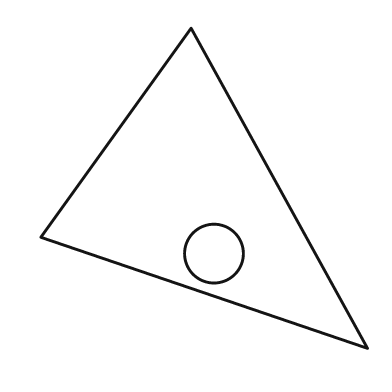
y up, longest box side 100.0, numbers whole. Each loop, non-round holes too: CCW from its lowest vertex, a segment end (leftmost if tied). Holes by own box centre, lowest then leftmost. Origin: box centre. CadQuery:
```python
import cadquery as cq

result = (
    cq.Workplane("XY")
    .moveTo(50.0, -49.0)
    .lineTo(-4.0, 49.0)
    .lineTo(-50.0, -15.0)
    .close()
    .moveTo(3.0, -20.0)
    .circle(9.0)
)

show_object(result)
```